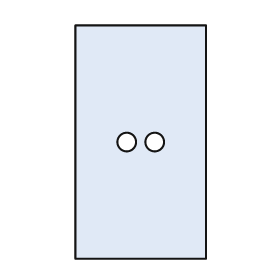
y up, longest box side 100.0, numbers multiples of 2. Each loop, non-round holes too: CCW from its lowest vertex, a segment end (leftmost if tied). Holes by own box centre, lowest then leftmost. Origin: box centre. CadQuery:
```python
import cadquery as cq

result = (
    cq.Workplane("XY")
    .moveTo(-28.0, -50.0)
    .lineTo(28.0, -50.0)
    .lineTo(28.0, 50.0)
    .lineTo(-28.0, 50.0)
    .close()
    .moveTo(-6.0, 0.0)
    .circle(4.0)
    .moveTo(6.0, 0.0)
    .circle(4.0)
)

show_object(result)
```